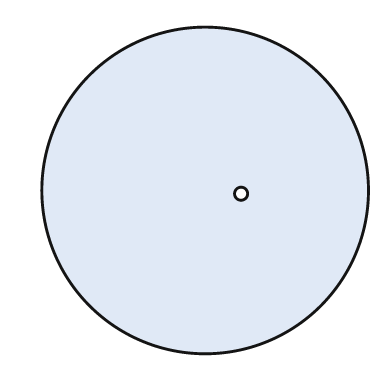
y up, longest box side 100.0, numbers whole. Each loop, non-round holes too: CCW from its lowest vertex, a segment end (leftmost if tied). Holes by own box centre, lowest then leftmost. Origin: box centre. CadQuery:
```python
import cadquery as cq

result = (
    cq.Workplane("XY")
    .moveTo(0.0, 0.0)
    .circle(50.0)
    .moveTo(11.0, -1.0)
    .circle(2.0)
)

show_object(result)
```